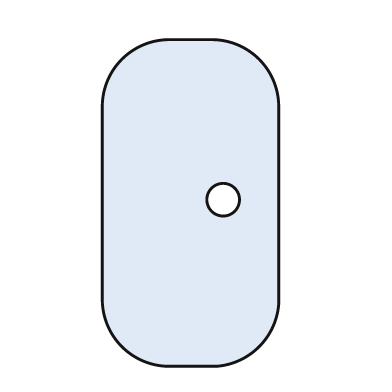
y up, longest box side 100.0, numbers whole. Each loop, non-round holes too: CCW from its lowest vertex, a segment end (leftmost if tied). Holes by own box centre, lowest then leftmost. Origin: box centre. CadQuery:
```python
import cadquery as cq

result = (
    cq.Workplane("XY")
    .moveTo(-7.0, -50.0)
    .lineTo(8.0, -50.0)
    .threePointArc((21.0, -44.0), (27.0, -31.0))
    .lineTo(27.0, 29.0)
    .threePointArc((21.0, 44.0), (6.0, 50.0))
    .lineTo(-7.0, 50.0)
    .threePointArc((-21.0, 44.0), (-27.0, 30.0))
    .lineTo(-27.0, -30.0)
    .threePointArc((-21.0, -44.0), (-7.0, -50.0))
    .close()
    .moveTo(10.0, 1.0)
    .circle(5.0)
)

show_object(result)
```